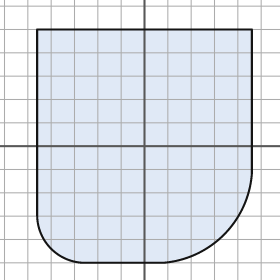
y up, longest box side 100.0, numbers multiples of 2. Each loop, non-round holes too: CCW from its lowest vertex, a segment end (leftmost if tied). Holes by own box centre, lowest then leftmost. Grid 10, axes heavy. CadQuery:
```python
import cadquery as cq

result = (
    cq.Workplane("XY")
    .moveTo(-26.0, -50.0)
    .lineTo(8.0, -50.0)
    .threePointArc((34.0, -38.0), (46.0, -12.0))
    .lineTo(46.0, 50.0)
    .lineTo(-46.0, 50.0)
    .lineTo(-46.0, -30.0)
    .threePointArc((-40.0, -44.0), (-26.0, -50.0))
    .close()
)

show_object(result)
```